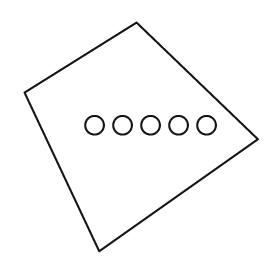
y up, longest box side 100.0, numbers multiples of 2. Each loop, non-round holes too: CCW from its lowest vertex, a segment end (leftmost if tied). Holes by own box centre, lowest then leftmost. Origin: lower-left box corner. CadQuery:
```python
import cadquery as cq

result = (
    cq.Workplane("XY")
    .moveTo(32.0, 0.0)
    .lineTo(100.0, 48.0)
    .lineTo(48.0, 98.0)
    .lineTo(0.0, 68.0)
    .close()
    .moveTo(30.0, 54.0)
    .circle(4.0)
    .moveTo(42.0, 54.0)
    .circle(4.0)
    .moveTo(54.0, 54.0)
    .circle(4.0)
    .moveTo(66.0, 54.0)
    .circle(4.0)
    .moveTo(78.0, 54.0)
    .circle(4.0)
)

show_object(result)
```